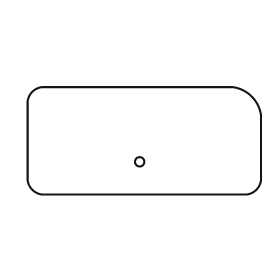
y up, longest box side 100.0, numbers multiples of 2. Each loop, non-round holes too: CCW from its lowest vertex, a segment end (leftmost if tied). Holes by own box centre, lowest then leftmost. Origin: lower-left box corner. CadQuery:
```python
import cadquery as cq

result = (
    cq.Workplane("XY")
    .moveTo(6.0, 0.0)
    .lineTo(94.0, 0.0)
    .threePointArc((98.0, 2.0), (100.0, 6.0))
    .lineTo(100.0, 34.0)
    .threePointArc((96.0, 42.0), (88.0, 46.0))
    .lineTo(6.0, 46.0)
    .threePointArc((2.0, 44.0), (0.0, 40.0))
    .lineTo(0.0, 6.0)
    .threePointArc((2.0, 2.0), (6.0, 0.0))
    .close()
    .moveTo(48.0, 14.0)
    .circle(2.0)
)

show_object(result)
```